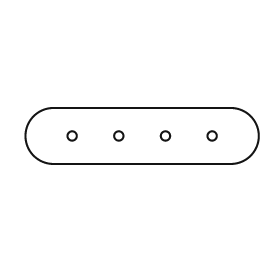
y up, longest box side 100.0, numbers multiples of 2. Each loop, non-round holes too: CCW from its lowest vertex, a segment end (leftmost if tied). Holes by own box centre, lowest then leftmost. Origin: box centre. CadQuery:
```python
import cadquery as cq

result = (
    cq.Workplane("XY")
    .moveTo(-38.0, -12.0)
    .lineTo(38.0, -12.0)
    .threePointArc((50.0, 0.0), (38.0, 12.0))
    .lineTo(-38.0, 12.0)
    .threePointArc((-50.0, 0.0), (-38.0, -12.0))
    .close()
    .moveTo(-30.0, 0.0)
    .circle(2.0)
    .moveTo(-10.0, 0.0)
    .circle(2.0)
    .moveTo(10.0, 0.0)
    .circle(2.0)
    .moveTo(30.0, 0.0)
    .circle(2.0)
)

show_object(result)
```